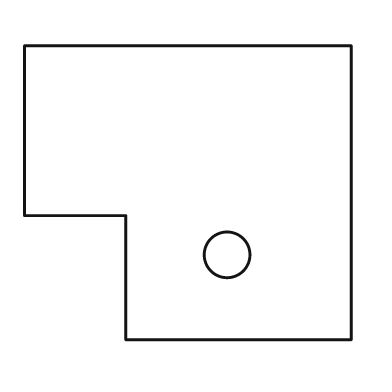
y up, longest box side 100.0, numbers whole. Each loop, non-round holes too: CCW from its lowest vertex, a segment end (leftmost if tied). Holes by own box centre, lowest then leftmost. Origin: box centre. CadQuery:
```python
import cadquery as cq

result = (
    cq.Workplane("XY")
    .moveTo(-19.0, -45.0)
    .lineTo(50.0, -45.0)
    .lineTo(50.0, 45.0)
    .lineTo(-50.0, 45.0)
    .lineTo(-50.0, -7.0)
    .lineTo(-19.0, -7.0)
    .close()
    .moveTo(12.0, -19.0)
    .circle(7.0)
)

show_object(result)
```